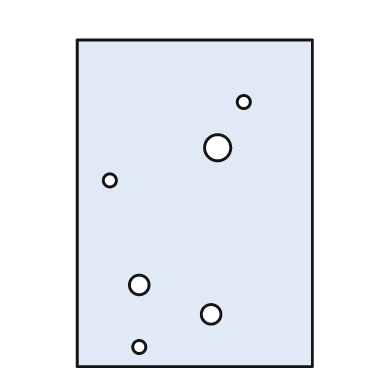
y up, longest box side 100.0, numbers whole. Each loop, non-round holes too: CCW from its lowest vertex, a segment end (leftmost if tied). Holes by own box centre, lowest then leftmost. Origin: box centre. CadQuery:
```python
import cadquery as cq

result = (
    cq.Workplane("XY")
    .moveTo(-36.0, -50.0)
    .lineTo(36.0, -50.0)
    .lineTo(36.0, 50.0)
    .lineTo(-36.0, 50.0)
    .close()
    .moveTo(-17.0, -44.0)
    .circle(2.0)
    .moveTo(5.0, -34.0)
    .circle(3.0)
    .moveTo(-17.0, -25.0)
    .circle(3.0)
    .moveTo(-26.0, 7.0)
    .circle(2.0)
    .moveTo(7.0, 17.0)
    .circle(4.0)
    .moveTo(15.0, 31.0)
    .circle(2.0)
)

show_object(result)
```